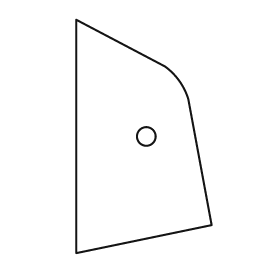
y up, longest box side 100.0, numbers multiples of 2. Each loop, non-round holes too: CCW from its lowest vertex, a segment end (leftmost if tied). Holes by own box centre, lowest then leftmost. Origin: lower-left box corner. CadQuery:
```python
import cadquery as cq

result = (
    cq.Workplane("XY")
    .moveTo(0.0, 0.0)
    .lineTo(58.0, 12.0)
    .lineTo(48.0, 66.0)
    .threePointArc((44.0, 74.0), (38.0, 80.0))
    .lineTo(0.0, 100.0)
    .close()
    .moveTo(30.0, 50.0)
    .circle(4.0)
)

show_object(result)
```